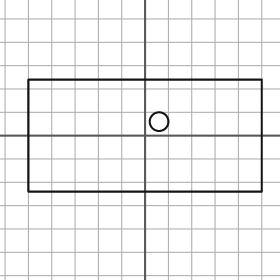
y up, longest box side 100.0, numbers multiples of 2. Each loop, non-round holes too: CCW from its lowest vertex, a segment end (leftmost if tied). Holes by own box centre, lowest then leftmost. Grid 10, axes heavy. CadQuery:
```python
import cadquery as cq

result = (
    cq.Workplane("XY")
    .moveTo(-50.0, -24.0)
    .lineTo(50.0, -24.0)
    .lineTo(50.0, 24.0)
    .lineTo(-50.0, 24.0)
    .close()
    .moveTo(6.0, 6.0)
    .circle(4.0)
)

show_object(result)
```